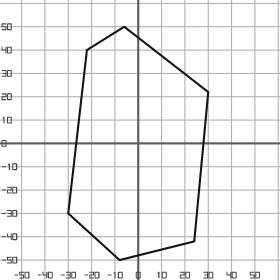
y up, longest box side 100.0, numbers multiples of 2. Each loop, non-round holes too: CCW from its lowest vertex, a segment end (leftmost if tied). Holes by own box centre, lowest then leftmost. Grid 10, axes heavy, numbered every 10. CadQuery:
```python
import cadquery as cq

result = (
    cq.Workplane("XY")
    .moveTo(-8.0, -50.0)
    .lineTo(24.0, -42.0)
    .lineTo(30.0, 22.0)
    .lineTo(-6.0, 50.0)
    .lineTo(-22.0, 40.0)
    .lineTo(-30.0, -30.0)
    .close()
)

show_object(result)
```